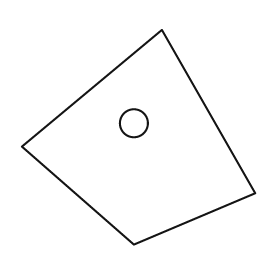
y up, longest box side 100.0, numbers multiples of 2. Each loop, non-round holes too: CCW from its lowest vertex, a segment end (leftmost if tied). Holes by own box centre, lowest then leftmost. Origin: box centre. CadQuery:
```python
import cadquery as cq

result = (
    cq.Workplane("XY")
    .moveTo(-2.0, -46.0)
    .lineTo(50.0, -24.0)
    .lineTo(10.0, 46.0)
    .lineTo(-50.0, -4.0)
    .close()
    .moveTo(-2.0, 6.0)
    .circle(6.0)
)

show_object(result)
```